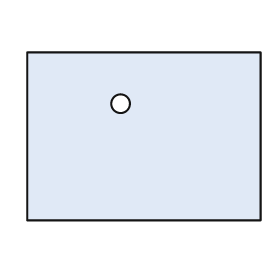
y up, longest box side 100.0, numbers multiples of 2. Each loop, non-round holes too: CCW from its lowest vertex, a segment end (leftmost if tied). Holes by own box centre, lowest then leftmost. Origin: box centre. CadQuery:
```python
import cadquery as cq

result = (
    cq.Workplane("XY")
    .moveTo(-50.0, -36.0)
    .lineTo(50.0, -36.0)
    .lineTo(50.0, 36.0)
    .lineTo(-50.0, 36.0)
    .close()
    .moveTo(-10.0, 14.0)
    .circle(4.0)
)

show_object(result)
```